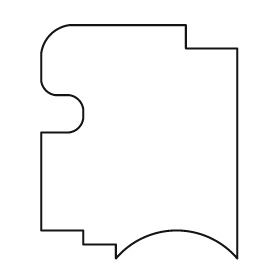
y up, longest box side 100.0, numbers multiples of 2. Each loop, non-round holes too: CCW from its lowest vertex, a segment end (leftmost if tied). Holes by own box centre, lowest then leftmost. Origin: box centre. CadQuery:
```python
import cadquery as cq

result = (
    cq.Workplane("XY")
    .moveTo(-10.0, -50.0)
    .threePointArc((16.0, -38.0), (42.0, -50.0))
    .lineTo(42.0, 40.0)
    .lineTo(20.0, 40.0)
    .lineTo(20.0, 50.0)
    .lineTo(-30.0, 50.0)
    .threePointArc((-38.0, 46.0), (-42.0, 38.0))
    .lineTo(-42.0, 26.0)
    .threePointArc((-40.0, 22.0), (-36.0, 20.0))
    .lineTo(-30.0, 20.0)
    .threePointArc((-26.0, 18.0), (-24.0, 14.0))
    .lineTo(-24.0, 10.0)
    .threePointArc((-26.0, 6.0), (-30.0, 4.0))
    .lineTo(-42.0, 4.0)
    .lineTo(-42.0, -38.0)
    .lineTo(-24.0, -38.0)
    .lineTo(-24.0, -44.0)
    .lineTo(-10.0, -44.0)
    .close()
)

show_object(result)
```